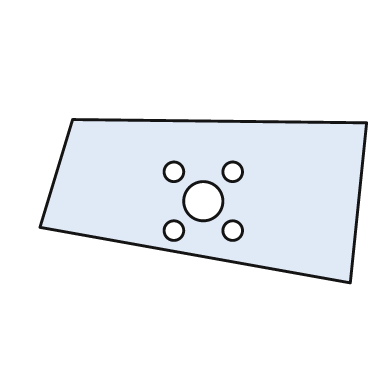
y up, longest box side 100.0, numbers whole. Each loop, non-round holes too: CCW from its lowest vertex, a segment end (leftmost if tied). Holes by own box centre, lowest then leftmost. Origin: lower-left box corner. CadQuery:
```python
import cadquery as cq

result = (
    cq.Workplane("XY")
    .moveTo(95.0, 0.0)
    .lineTo(100.0, 49.0)
    .lineTo(10.0, 50.0)
    .lineTo(0.0, 17.0)
    .close()
    .moveTo(41.0, 16.0)
    .circle(3.0)
    .moveTo(59.0, 16.0)
    .circle(3.0)
    .moveTo(50.0, 25.0)
    .circle(6.0)
    .moveTo(41.0, 34.0)
    .circle(3.0)
    .moveTo(59.0, 34.0)
    .circle(3.0)
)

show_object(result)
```